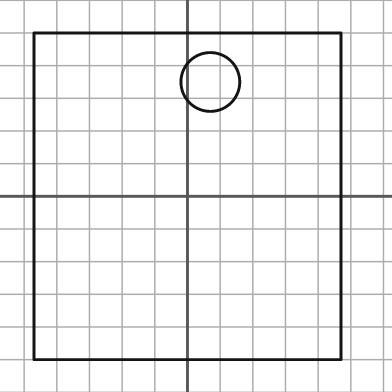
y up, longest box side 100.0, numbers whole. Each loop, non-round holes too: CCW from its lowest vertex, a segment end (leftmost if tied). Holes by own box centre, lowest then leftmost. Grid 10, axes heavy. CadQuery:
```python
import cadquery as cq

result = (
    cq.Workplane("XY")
    .moveTo(-47.0, -50.0)
    .lineTo(47.0, -50.0)
    .lineTo(47.0, 50.0)
    .lineTo(-47.0, 50.0)
    .close()
    .moveTo(7.0, 35.0)
    .circle(9.0)
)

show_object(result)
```